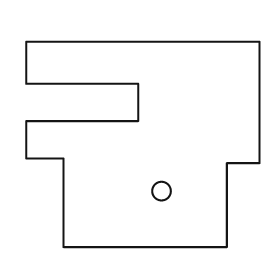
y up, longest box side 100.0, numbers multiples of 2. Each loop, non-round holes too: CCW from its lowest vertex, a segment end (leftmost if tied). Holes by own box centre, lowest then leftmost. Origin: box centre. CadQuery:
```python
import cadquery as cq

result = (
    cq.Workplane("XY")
    .moveTo(-34.0, -44.0)
    .lineTo(36.0, -44.0)
    .lineTo(36.0, -8.0)
    .lineTo(50.0, -8.0)
    .lineTo(50.0, 44.0)
    .lineTo(-50.0, 44.0)
    .lineTo(-50.0, 26.0)
    .lineTo(-2.0, 26.0)
    .lineTo(-2.0, 10.0)
    .lineTo(-50.0, 10.0)
    .lineTo(-50.0, -6.0)
    .lineTo(-34.0, -6.0)
    .close()
    .moveTo(8.0, -20.0)
    .circle(4.0)
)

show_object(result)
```